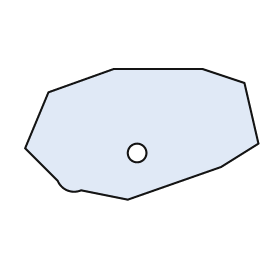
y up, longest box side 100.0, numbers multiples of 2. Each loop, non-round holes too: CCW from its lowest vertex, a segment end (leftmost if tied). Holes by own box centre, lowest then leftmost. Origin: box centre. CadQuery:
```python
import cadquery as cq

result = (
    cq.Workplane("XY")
    .moveTo(-6.0, -28.0)
    .lineTo(34.0, -14.0)
    .lineTo(50.0, -4.0)
    .lineTo(44.0, 22.0)
    .lineTo(26.0, 28.0)
    .lineTo(-12.0, 28.0)
    .lineTo(-40.0, 18.0)
    .lineTo(-50.0, -6.0)
    .lineTo(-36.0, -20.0)
    .threePointArc((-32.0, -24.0), (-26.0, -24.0))
    .close()
    .moveTo(-2.0, -8.0)
    .circle(4.0)
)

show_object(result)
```